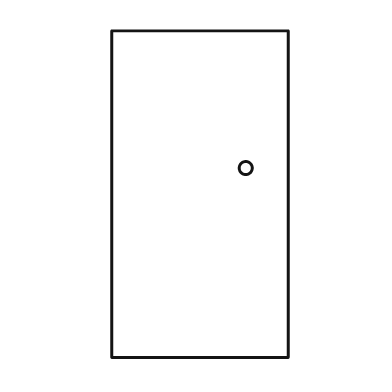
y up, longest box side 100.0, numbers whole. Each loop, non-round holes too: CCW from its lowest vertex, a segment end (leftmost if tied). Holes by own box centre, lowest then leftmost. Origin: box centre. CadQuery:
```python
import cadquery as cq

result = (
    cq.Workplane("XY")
    .moveTo(-27.0, -50.0)
    .lineTo(27.0, -50.0)
    .lineTo(27.0, 50.0)
    .lineTo(-27.0, 50.0)
    .close()
    .moveTo(14.0, 8.0)
    .circle(2.0)
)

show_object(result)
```